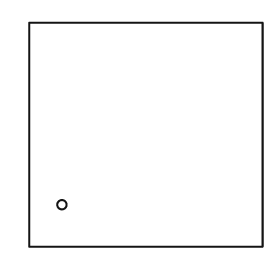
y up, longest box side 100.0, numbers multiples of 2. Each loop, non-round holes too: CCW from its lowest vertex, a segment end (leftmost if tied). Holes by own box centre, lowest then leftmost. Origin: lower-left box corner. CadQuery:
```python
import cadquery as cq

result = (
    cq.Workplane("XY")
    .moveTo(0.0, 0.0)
    .lineTo(100.0, 0.0)
    .lineTo(100.0, 96.0)
    .lineTo(0.0, 96.0)
    .close()
    .moveTo(14.0, 18.0)
    .circle(2.0)
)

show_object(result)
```